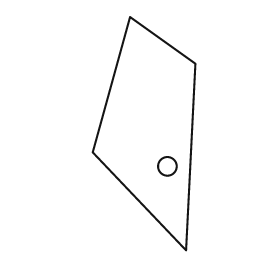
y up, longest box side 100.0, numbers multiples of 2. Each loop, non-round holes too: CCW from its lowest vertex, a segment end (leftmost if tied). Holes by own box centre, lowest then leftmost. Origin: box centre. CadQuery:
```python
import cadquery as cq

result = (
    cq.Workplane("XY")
    .moveTo(18.0, -50.0)
    .lineTo(22.0, 30.0)
    .lineTo(-6.0, 50.0)
    .lineTo(-22.0, -8.0)
    .close()
    .moveTo(10.0, -14.0)
    .circle(4.0)
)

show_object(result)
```